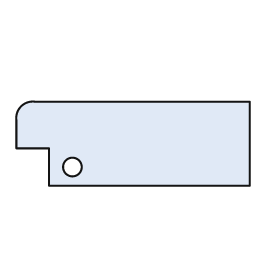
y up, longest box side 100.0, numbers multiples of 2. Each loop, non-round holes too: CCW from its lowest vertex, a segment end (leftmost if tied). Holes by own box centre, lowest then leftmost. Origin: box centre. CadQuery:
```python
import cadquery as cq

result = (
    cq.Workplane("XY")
    .moveTo(-36.0, -18.0)
    .lineTo(50.0, -18.0)
    .lineTo(50.0, 18.0)
    .lineTo(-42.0, 18.0)
    .threePointArc((-48.0, 16.0), (-50.0, 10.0))
    .lineTo(-50.0, -2.0)
    .lineTo(-36.0, -2.0)
    .close()
    .moveTo(-26.0, -10.0)
    .circle(4.0)
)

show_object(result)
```